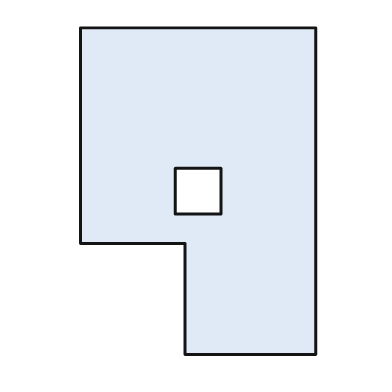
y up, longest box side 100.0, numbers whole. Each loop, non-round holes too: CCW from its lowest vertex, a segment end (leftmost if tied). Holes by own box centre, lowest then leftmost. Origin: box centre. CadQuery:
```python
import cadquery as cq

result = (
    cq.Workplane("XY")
    .moveTo(-4.0, -50.0)
    .lineTo(36.0, -50.0)
    .lineTo(36.0, 50.0)
    .lineTo(-36.0, 50.0)
    .lineTo(-36.0, -16.0)
    .lineTo(-4.0, -16.0)
    .close()
    .moveTo(-7.0, -7.0)
    .lineTo(7.0, -7.0)
    .lineTo(7.0, 7.0)
    .lineTo(-7.0, 7.0)
    .close()
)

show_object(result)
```